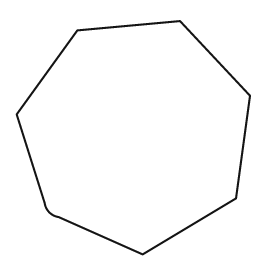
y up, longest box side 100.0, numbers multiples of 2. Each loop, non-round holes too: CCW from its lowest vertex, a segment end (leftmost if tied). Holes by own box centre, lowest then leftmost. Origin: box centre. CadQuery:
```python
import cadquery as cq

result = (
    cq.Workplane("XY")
    .moveTo(4.0, -50.0)
    .lineTo(44.0, -26.0)
    .lineTo(50.0, 18.0)
    .lineTo(20.0, 50.0)
    .lineTo(-24.0, 46.0)
    .lineTo(-50.0, 10.0)
    .lineTo(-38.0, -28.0)
    .threePointArc((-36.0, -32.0), (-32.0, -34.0))
    .close()
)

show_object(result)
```